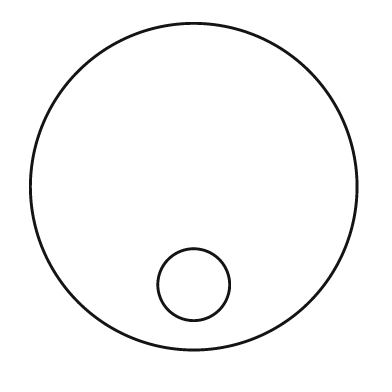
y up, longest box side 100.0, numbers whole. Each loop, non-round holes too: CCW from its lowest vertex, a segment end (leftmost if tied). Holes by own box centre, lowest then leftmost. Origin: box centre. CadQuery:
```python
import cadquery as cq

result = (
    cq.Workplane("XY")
    .moveTo(0.0, 0.0)
    .circle(50.0)
    .moveTo(0.0, -30.0)
    .circle(11.0)
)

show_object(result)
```